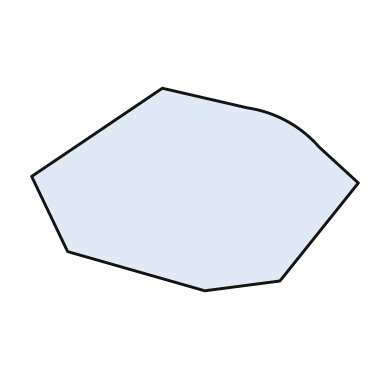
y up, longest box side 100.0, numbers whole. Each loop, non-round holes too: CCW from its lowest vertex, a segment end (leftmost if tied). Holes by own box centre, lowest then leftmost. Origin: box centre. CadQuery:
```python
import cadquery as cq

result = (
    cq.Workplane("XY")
    .moveTo(3.0, -31.0)
    .lineTo(26.0, -28.0)
    .lineTo(50.0, 2.0)
    .lineTo(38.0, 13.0)
    .threePointArc((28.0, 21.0), (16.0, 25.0))
    .lineTo(-10.0, 31.0)
    .lineTo(-50.0, 4.0)
    .lineTo(-39.0, -19.0)
    .close()
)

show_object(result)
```